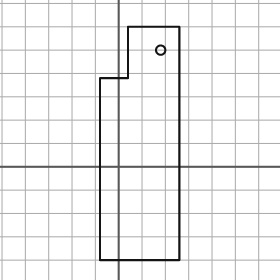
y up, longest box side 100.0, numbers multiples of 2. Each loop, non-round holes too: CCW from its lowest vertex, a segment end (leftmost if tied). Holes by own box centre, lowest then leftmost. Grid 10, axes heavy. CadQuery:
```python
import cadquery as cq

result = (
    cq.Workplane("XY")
    .moveTo(-8.0, -40.0)
    .lineTo(26.0, -40.0)
    .lineTo(26.0, 60.0)
    .lineTo(4.0, 60.0)
    .lineTo(4.0, 38.0)
    .lineTo(-8.0, 38.0)
    .close()
    .moveTo(18.0, 50.0)
    .circle(2.0)
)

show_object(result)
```